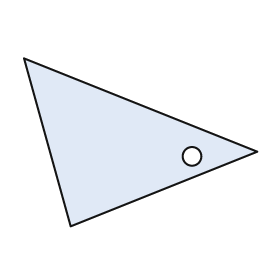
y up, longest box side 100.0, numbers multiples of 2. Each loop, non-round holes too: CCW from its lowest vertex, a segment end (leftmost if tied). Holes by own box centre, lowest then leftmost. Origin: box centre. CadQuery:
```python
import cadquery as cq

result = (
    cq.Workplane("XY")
    .moveTo(-30.0, -36.0)
    .lineTo(50.0, -4.0)
    .lineTo(-50.0, 36.0)
    .close()
    .moveTo(22.0, -6.0)
    .circle(4.0)
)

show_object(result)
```